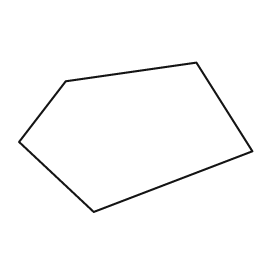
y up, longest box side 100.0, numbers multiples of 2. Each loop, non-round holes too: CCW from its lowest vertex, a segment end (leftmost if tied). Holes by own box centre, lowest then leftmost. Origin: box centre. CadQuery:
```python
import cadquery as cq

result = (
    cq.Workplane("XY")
    .moveTo(-18.0, -32.0)
    .lineTo(50.0, -6.0)
    .lineTo(26.0, 32.0)
    .lineTo(-30.0, 24.0)
    .lineTo(-50.0, -2.0)
    .close()
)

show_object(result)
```